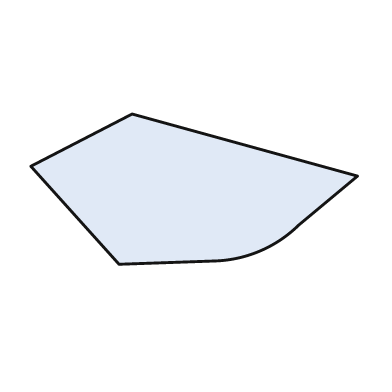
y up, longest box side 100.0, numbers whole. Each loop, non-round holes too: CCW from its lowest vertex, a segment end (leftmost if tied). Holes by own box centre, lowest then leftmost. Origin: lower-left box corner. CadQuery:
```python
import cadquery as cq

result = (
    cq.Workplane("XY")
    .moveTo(27.0, 0.0)
    .lineTo(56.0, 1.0)
    .threePointArc((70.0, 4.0), (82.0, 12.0))
    .lineTo(100.0, 27.0)
    .lineTo(31.0, 46.0)
    .lineTo(0.0, 30.0)
    .close()
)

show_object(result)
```